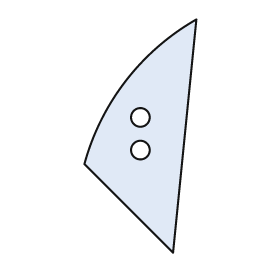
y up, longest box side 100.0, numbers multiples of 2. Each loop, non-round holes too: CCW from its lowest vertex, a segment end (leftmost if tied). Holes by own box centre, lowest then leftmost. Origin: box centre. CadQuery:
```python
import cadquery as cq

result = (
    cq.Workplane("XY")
    .moveTo(14.0, -50.0)
    .lineTo(24.0, 50.0)
    .threePointArc((-6.0, 24.0), (-24.0, -12.0))
    .close()
    .moveTo(0.0, -6.0)
    .circle(4.0)
    .moveTo(0.0, 8.0)
    .circle(4.0)
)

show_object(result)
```